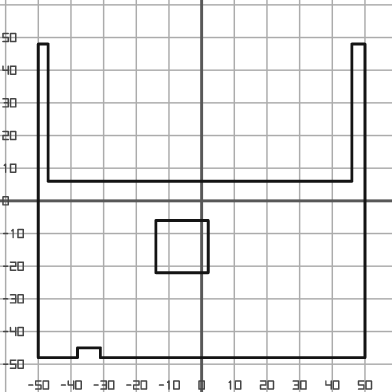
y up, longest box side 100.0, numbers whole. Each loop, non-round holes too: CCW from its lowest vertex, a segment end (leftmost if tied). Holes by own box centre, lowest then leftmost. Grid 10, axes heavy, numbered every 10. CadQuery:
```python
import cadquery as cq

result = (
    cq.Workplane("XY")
    .moveTo(-50.0, -48.0)
    .lineTo(-38.0, -48.0)
    .lineTo(-38.0, -45.0)
    .lineTo(-31.0, -45.0)
    .lineTo(-31.0, -48.0)
    .lineTo(50.0, -48.0)
    .lineTo(50.0, 48.0)
    .lineTo(46.0, 48.0)
    .lineTo(46.0, 6.0)
    .lineTo(-47.0, 6.0)
    .lineTo(-47.0, 48.0)
    .lineTo(-50.0, 48.0)
    .close()
    .moveTo(-14.0, -22.0)
    .lineTo(2.0, -22.0)
    .lineTo(2.0, -6.0)
    .lineTo(-14.0, -6.0)
    .close()
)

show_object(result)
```